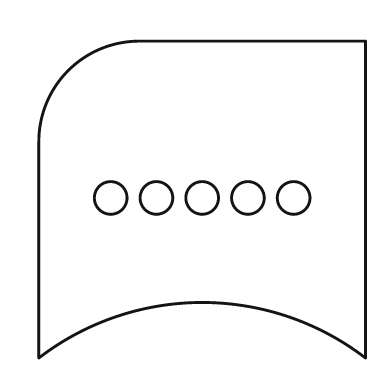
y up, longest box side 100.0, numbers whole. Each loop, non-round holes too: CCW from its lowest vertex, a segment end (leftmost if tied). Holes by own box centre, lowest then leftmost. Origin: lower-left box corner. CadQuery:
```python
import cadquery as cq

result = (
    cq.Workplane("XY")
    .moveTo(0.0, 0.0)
    .threePointArc((50.0, 17.0), (100.0, 0.0))
    .lineTo(100.0, 97.0)
    .lineTo(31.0, 97.0)
    .threePointArc((9.0, 88.0), (0.0, 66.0))
    .close()
    .moveTo(22.0, 49.0)
    .circle(5.0)
    .moveTo(36.0, 49.0)
    .circle(5.0)
    .moveTo(50.0, 49.0)
    .circle(5.0)
    .moveTo(64.0, 49.0)
    .circle(5.0)
    .moveTo(78.0, 49.0)
    .circle(5.0)
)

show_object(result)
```